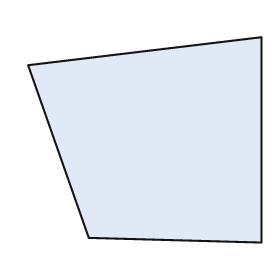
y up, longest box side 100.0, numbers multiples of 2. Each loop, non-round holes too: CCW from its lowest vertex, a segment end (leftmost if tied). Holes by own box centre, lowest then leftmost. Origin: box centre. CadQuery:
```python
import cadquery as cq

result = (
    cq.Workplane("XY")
    .moveTo(50.0, -44.0)
    .lineTo(50.0, 44.0)
    .lineTo(-50.0, 32.0)
    .lineTo(-24.0, -42.0)
    .close()
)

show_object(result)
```